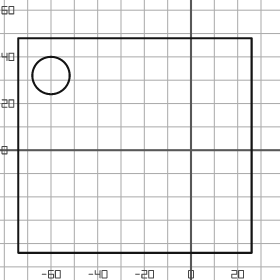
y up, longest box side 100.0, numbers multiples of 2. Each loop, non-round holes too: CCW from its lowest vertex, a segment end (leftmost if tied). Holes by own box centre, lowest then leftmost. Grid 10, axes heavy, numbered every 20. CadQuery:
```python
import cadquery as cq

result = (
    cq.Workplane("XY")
    .moveTo(-74.0, -44.0)
    .lineTo(26.0, -44.0)
    .lineTo(26.0, 48.0)
    .lineTo(-74.0, 48.0)
    .close()
    .moveTo(-60.0, 32.0)
    .circle(8.0)
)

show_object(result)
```